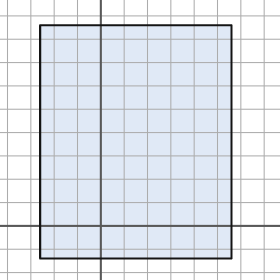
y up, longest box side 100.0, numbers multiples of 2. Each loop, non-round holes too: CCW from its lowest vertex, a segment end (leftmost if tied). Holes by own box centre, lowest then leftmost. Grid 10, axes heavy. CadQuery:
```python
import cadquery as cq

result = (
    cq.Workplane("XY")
    .moveTo(-26.0, -14.0)
    .lineTo(56.0, -14.0)
    .lineTo(56.0, 86.0)
    .lineTo(-26.0, 86.0)
    .close()
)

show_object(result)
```